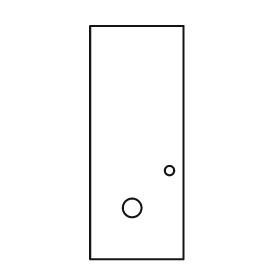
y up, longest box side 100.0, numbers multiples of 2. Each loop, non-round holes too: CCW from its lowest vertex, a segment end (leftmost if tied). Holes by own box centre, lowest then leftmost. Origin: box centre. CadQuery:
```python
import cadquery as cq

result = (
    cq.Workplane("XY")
    .moveTo(-20.0, -50.0)
    .lineTo(20.0, -50.0)
    .lineTo(20.0, 50.0)
    .lineTo(-20.0, 50.0)
    .close()
    .moveTo(-2.0, -28.0)
    .circle(4.0)
    .moveTo(14.0, -12.0)
    .circle(2.0)
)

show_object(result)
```